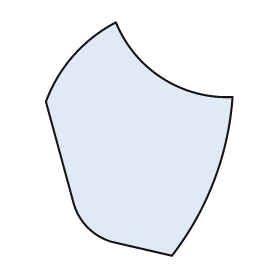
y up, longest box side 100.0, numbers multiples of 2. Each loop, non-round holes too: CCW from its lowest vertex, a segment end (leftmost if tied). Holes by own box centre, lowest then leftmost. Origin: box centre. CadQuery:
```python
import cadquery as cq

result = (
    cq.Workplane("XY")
    .moveTo(14.0, -50.0)
    .threePointArc((32.0, -18.0), (40.0, 18.0))
    .threePointArc((10.0, 26.0), (-10.0, 50.0))
    .threePointArc((-28.0, 36.0), (-40.0, 16.0))
    .lineTo(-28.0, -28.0)
    .threePointArc((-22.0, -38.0), (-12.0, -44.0))
    .close()
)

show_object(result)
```